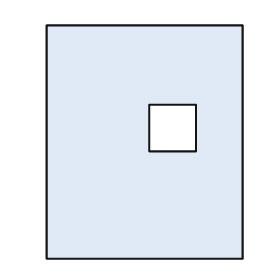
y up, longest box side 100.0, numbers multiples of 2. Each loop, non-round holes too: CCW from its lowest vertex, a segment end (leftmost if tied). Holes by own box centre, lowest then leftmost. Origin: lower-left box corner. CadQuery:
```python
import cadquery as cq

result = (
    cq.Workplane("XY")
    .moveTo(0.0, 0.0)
    .lineTo(84.0, 0.0)
    .lineTo(84.0, 100.0)
    .lineTo(0.0, 100.0)
    .close()
    .moveTo(44.0, 46.0)
    .lineTo(64.0, 46.0)
    .lineTo(64.0, 66.0)
    .lineTo(44.0, 66.0)
    .close()
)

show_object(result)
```